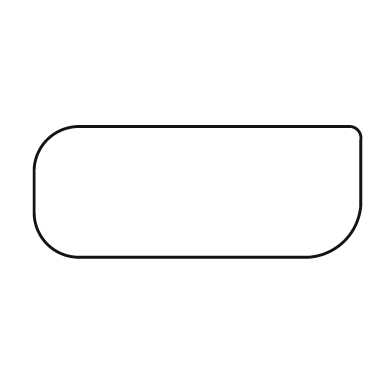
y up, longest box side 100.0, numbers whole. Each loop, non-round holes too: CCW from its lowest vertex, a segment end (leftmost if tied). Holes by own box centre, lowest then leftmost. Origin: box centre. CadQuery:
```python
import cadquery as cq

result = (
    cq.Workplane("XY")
    .moveTo(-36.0, -20.0)
    .lineTo(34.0, -20.0)
    .threePointArc((45.0, -15.0), (50.0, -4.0))
    .lineTo(50.0, 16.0)
    .threePointArc((49.0, 19.0), (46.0, 20.0))
    .lineTo(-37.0, 20.0)
    .threePointArc((-46.0, 16.0), (-50.0, 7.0))
    .lineTo(-50.0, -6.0)
    .threePointArc((-46.0, -16.0), (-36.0, -20.0))
    .close()
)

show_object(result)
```